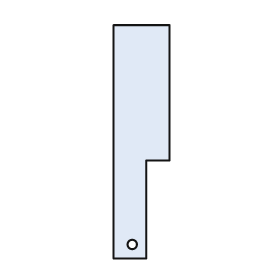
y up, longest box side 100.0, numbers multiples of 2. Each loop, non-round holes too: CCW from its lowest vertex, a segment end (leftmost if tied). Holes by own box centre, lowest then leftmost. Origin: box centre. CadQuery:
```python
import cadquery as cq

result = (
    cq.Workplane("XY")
    .moveTo(-12.0, -50.0)
    .lineTo(2.0, -50.0)
    .lineTo(2.0, -8.0)
    .lineTo(12.0, -8.0)
    .lineTo(12.0, 50.0)
    .lineTo(-12.0, 50.0)
    .close()
    .moveTo(-4.0, -44.0)
    .circle(2.0)
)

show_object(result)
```